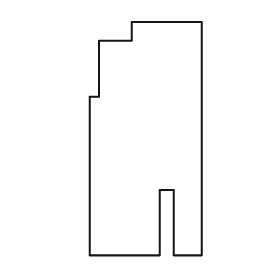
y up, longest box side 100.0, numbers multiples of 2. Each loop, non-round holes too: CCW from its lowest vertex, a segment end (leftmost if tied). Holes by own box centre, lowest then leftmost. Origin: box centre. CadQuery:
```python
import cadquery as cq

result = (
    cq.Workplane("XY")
    .moveTo(-24.0, -50.0)
    .lineTo(6.0, -50.0)
    .lineTo(6.0, -22.0)
    .lineTo(12.0, -22.0)
    .lineTo(12.0, -50.0)
    .lineTo(24.0, -50.0)
    .lineTo(24.0, 50.0)
    .lineTo(-6.0, 50.0)
    .lineTo(-6.0, 42.0)
    .lineTo(-20.0, 42.0)
    .lineTo(-20.0, 18.0)
    .lineTo(-24.0, 18.0)
    .close()
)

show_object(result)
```